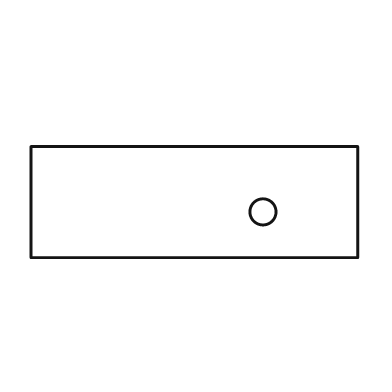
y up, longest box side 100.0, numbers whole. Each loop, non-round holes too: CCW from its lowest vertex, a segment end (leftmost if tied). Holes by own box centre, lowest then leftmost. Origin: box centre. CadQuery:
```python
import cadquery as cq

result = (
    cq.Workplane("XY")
    .moveTo(-50.0, -17.0)
    .lineTo(50.0, -17.0)
    .lineTo(50.0, 17.0)
    .lineTo(-50.0, 17.0)
    .close()
    .moveTo(21.0, -3.0)
    .circle(4.0)
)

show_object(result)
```